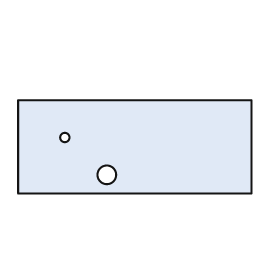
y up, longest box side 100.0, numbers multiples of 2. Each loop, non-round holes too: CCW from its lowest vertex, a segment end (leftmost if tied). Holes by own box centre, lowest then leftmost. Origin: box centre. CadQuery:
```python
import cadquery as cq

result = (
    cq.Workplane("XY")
    .moveTo(-50.0, -20.0)
    .lineTo(50.0, -20.0)
    .lineTo(50.0, 20.0)
    .lineTo(-50.0, 20.0)
    .close()
    .moveTo(-12.0, -12.0)
    .circle(4.0)
    .moveTo(-30.0, 4.0)
    .circle(2.0)
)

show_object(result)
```